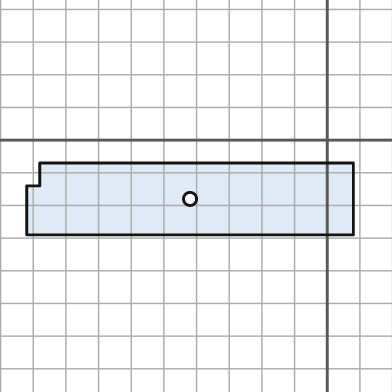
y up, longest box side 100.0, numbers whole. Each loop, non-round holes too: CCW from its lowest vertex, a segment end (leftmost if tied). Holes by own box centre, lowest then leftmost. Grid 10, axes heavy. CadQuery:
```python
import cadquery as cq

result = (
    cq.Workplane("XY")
    .moveTo(-92.0, -29.0)
    .lineTo(8.0, -29.0)
    .lineTo(8.0, -7.0)
    .lineTo(-88.0, -7.0)
    .lineTo(-88.0, -14.0)
    .lineTo(-92.0, -14.0)
    .close()
    .moveTo(-42.0, -18.0)
    .circle(2.0)
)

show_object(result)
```